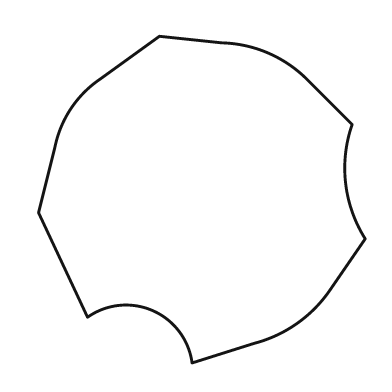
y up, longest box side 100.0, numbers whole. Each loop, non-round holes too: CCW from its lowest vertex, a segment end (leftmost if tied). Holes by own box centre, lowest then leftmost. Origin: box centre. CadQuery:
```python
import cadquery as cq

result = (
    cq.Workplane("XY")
    .moveTo(-3.0, -50.0)
    .lineTo(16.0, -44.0)
    .threePointArc((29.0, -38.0), (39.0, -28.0))
    .lineTo(50.0, -12.0)
    .threePointArc((44.0, 5.0), (46.0, 23.0))
    .lineTo(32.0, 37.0)
    .threePointArc((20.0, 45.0), (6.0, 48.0))
    .lineTo(-13.0, 50.0)
    .lineTo(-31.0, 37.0)
    .threePointArc((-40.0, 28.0), (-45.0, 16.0))
    .lineTo(-50.0, -4.0)
    .lineTo(-35.0, -36.0)
    .threePointArc((-15.0, -34.0), (-3.0, -50.0))
    .close()
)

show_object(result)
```